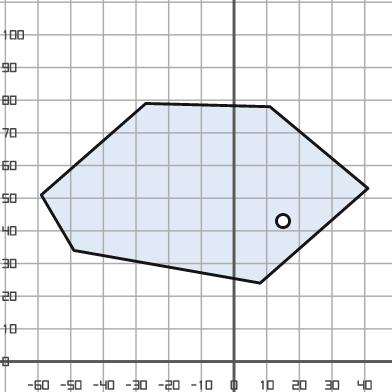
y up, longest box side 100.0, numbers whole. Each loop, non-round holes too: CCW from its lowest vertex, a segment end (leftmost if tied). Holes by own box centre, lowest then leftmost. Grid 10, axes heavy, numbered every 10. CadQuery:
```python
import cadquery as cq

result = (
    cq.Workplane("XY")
    .moveTo(8.0, 24.0)
    .lineTo(41.0, 53.0)
    .lineTo(11.0, 78.0)
    .lineTo(-27.0, 79.0)
    .lineTo(-59.0, 51.0)
    .lineTo(-49.0, 34.0)
    .close()
    .moveTo(15.0, 43.0)
    .circle(2.0)
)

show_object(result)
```